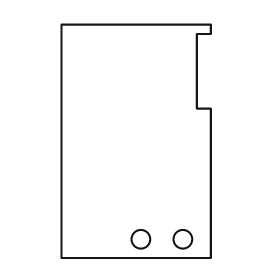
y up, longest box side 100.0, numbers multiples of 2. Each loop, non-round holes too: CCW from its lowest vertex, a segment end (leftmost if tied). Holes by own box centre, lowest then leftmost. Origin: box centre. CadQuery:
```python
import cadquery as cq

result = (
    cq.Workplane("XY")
    .moveTo(-32.0, -50.0)
    .lineTo(32.0, -50.0)
    .lineTo(32.0, 14.0)
    .lineTo(26.0, 14.0)
    .lineTo(26.0, 46.0)
    .lineTo(32.0, 46.0)
    .lineTo(32.0, 50.0)
    .lineTo(-32.0, 50.0)
    .close()
    .moveTo(2.0, -42.0)
    .circle(4.0)
    .moveTo(20.0, -42.0)
    .circle(4.0)
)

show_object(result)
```